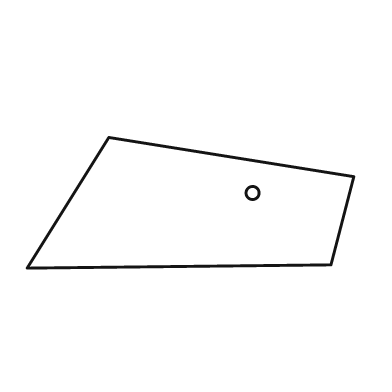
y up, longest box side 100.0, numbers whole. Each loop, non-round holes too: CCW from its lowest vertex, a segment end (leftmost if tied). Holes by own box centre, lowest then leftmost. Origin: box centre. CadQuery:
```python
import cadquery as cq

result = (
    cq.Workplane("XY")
    .moveTo(-50.0, -20.0)
    .lineTo(43.0, -19.0)
    .lineTo(50.0, 8.0)
    .lineTo(-25.0, 20.0)
    .close()
    .moveTo(19.0, 3.0)
    .circle(2.0)
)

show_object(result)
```